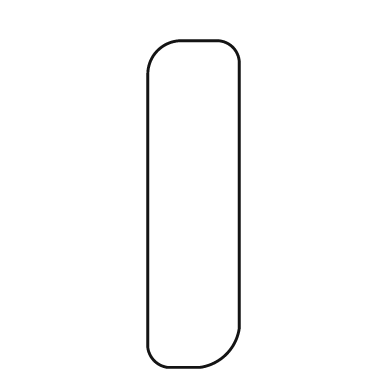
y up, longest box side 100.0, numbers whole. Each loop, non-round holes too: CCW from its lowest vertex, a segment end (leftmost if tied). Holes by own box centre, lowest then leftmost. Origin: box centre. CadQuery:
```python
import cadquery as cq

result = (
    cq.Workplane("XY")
    .moveTo(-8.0, -50.0)
    .lineTo(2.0, -50.0)
    .threePointArc((10.0, -46.0), (14.0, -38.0))
    .lineTo(14.0, 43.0)
    .threePointArc((12.0, 48.0), (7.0, 50.0))
    .lineTo(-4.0, 50.0)
    .threePointArc((-11.0, 47.0), (-14.0, 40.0))
    .lineTo(-14.0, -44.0)
    .threePointArc((-12.0, -48.0), (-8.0, -50.0))
    .close()
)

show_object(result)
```